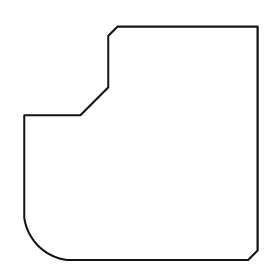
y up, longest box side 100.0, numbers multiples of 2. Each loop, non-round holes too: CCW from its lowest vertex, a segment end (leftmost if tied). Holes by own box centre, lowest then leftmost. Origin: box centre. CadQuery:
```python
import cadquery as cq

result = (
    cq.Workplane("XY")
    .moveTo(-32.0, -50.0)
    .lineTo(46.0, -50.0)
    .lineTo(50.0, -46.0)
    .lineTo(50.0, 50.0)
    .lineTo(-10.0, 50.0)
    .lineTo(-14.0, 46.0)
    .lineTo(-14.0, 24.0)
    .lineTo(-26.0, 12.0)
    .lineTo(-50.0, 12.0)
    .lineTo(-50.0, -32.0)
    .threePointArc((-44.0, -44.0), (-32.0, -50.0))
    .close()
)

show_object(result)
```